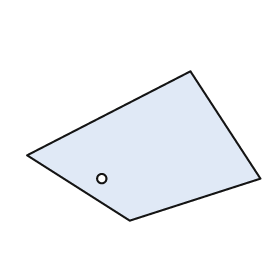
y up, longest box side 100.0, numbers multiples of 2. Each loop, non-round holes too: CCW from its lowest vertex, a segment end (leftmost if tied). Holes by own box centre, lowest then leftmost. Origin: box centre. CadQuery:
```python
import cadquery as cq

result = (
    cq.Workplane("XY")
    .moveTo(-6.0, -32.0)
    .lineTo(50.0, -14.0)
    .lineTo(20.0, 32.0)
    .lineTo(-50.0, -4.0)
    .close()
    .moveTo(-18.0, -14.0)
    .circle(2.0)
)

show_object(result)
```